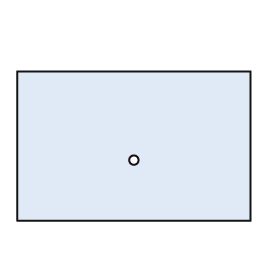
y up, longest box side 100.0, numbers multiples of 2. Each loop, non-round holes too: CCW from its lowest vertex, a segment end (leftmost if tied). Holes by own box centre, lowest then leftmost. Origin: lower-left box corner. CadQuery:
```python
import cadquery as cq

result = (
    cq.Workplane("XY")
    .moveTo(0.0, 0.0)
    .lineTo(100.0, 0.0)
    .lineTo(100.0, 64.0)
    .lineTo(0.0, 64.0)
    .close()
    .moveTo(50.0, 26.0)
    .circle(2.0)
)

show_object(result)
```